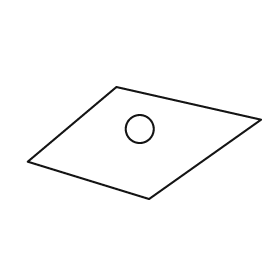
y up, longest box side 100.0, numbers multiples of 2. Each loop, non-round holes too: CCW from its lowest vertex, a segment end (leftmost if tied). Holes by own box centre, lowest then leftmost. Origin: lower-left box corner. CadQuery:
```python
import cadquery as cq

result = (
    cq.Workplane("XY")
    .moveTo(52.0, 0.0)
    .lineTo(100.0, 34.0)
    .lineTo(38.0, 48.0)
    .lineTo(0.0, 16.0)
    .close()
    .moveTo(48.0, 30.0)
    .circle(6.0)
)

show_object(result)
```